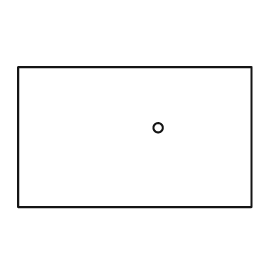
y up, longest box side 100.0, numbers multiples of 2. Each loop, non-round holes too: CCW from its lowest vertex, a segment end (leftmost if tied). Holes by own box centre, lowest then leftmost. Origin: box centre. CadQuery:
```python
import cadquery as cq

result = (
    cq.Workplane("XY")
    .moveTo(-50.0, -30.0)
    .lineTo(50.0, -30.0)
    .lineTo(50.0, 30.0)
    .lineTo(-50.0, 30.0)
    .close()
    .moveTo(10.0, 4.0)
    .circle(2.0)
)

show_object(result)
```